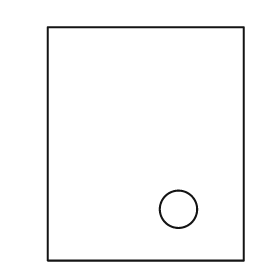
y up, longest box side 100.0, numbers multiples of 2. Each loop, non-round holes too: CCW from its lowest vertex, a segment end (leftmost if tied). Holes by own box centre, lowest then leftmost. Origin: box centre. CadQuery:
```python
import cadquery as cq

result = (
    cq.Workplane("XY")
    .moveTo(-42.0, -50.0)
    .lineTo(42.0, -50.0)
    .lineTo(42.0, 50.0)
    .lineTo(-42.0, 50.0)
    .close()
    .moveTo(14.0, -28.0)
    .circle(8.0)
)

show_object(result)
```